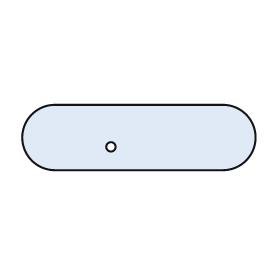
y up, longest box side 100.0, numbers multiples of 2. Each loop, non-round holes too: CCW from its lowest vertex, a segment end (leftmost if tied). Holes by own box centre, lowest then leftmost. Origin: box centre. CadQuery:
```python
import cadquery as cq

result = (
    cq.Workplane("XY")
    .moveTo(-36.0, -14.0)
    .lineTo(36.0, -14.0)
    .threePointArc((50.0, 0.0), (36.0, 14.0))
    .lineTo(-36.0, 14.0)
    .threePointArc((-50.0, 0.0), (-36.0, -14.0))
    .close()
    .moveTo(-12.0, -4.0)
    .circle(2.0)
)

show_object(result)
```